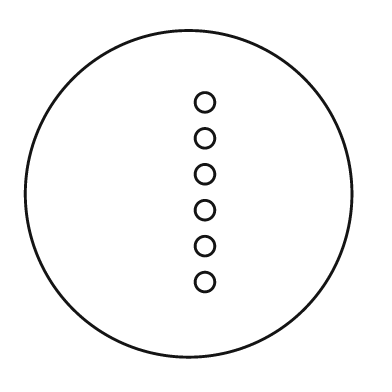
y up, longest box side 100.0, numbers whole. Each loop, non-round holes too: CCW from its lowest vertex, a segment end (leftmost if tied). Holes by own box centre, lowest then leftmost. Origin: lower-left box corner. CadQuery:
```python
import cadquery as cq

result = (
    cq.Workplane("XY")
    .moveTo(50.0, 50.0)
    .circle(50.0)
    .moveTo(55.0, 23.0)
    .circle(3.0)
    .moveTo(55.0, 34.0)
    .circle(3.0)
    .moveTo(55.0, 45.0)
    .circle(3.0)
    .moveTo(55.0, 56.0)
    .circle(3.0)
    .moveTo(55.0, 67.0)
    .circle(3.0)
    .moveTo(55.0, 78.0)
    .circle(3.0)
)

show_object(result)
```